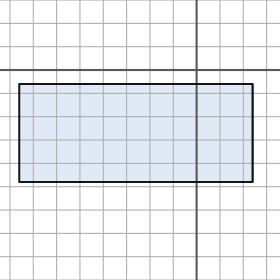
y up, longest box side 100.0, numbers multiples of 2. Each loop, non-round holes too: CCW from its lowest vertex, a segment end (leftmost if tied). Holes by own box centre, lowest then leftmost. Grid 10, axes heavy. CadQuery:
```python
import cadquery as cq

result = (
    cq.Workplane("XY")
    .moveTo(-76.0, -48.0)
    .lineTo(24.0, -48.0)
    .lineTo(24.0, -6.0)
    .lineTo(-76.0, -6.0)
    .close()
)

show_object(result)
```